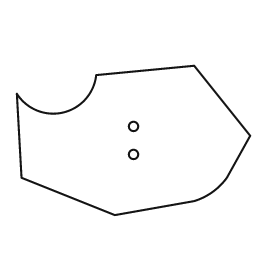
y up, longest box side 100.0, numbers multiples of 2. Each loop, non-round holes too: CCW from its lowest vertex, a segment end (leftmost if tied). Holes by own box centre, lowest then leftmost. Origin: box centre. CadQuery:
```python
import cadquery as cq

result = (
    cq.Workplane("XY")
    .moveTo(-8.0, -32.0)
    .lineTo(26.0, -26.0)
    .threePointArc((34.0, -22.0), (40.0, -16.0))
    .lineTo(50.0, 2.0)
    .lineTo(26.0, 32.0)
    .lineTo(-16.0, 28.0)
    .threePointArc((-30.0, 12.0), (-50.0, 20.0))
    .lineTo(-48.0, -16.0)
    .close()
    .moveTo(0.0, -6.0)
    .circle(2.0)
    .moveTo(0.0, 6.0)
    .circle(2.0)
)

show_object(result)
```